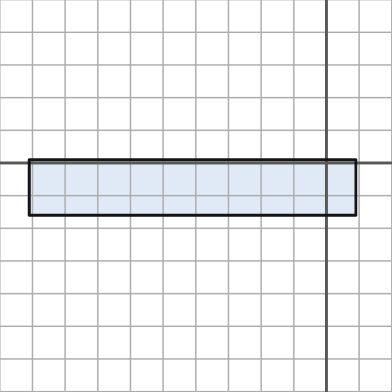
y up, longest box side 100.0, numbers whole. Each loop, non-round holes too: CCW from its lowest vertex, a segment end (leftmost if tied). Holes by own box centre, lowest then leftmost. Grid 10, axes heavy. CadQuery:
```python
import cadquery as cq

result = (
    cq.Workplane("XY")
    .moveTo(-91.0, -16.0)
    .lineTo(9.0, -16.0)
    .lineTo(9.0, 1.0)
    .lineTo(-91.0, 1.0)
    .close()
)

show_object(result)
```